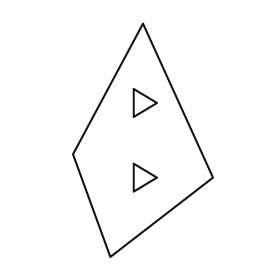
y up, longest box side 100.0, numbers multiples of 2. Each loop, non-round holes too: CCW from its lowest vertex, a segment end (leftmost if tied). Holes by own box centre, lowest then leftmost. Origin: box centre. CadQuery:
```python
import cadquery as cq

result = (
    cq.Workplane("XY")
    .moveTo(-14.0, -50.0)
    .lineTo(30.0, -16.0)
    .lineTo(0.0, 50.0)
    .lineTo(-30.0, -6.0)
    .close()
    .moveTo(-4.0, -22.0)
    .lineTo(6.0, -16.0)
    .lineTo(-4.0, -10.0)
    .close()
    .moveTo(-4.0, 10.0)
    .lineTo(6.0, 16.0)
    .lineTo(-4.0, 22.0)
    .close()
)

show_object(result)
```